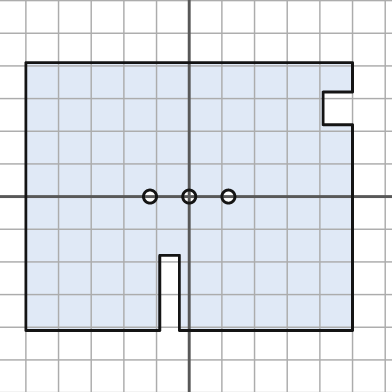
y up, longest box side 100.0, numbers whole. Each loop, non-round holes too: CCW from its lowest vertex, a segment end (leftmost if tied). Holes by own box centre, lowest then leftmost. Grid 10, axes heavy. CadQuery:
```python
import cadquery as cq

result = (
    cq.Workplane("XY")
    .moveTo(-50.0, -41.0)
    .lineTo(-9.0, -41.0)
    .lineTo(-9.0, -18.0)
    .lineTo(-3.0, -18.0)
    .lineTo(-3.0, -41.0)
    .lineTo(50.0, -41.0)
    .lineTo(50.0, 22.0)
    .lineTo(41.0, 22.0)
    .lineTo(41.0, 32.0)
    .lineTo(50.0, 32.0)
    .lineTo(50.0, 41.0)
    .lineTo(-50.0, 41.0)
    .close()
    .moveTo(-12.0, 0.0)
    .circle(2.0)
    .moveTo(0.0, 0.0)
    .circle(2.0)
    .moveTo(12.0, 0.0)
    .circle(2.0)
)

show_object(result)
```